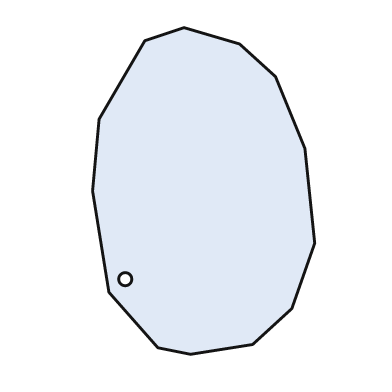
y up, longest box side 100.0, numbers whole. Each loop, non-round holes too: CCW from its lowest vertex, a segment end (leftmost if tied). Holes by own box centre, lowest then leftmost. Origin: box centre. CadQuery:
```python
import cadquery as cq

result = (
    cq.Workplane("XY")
    .moveTo(-4.0, -50.0)
    .lineTo(15.0, -47.0)
    .lineTo(27.0, -36.0)
    .lineTo(34.0, -16.0)
    .lineTo(31.0, 13.0)
    .lineTo(22.0, 35.0)
    .lineTo(11.0, 45.0)
    .lineTo(-6.0, 50.0)
    .lineTo(-18.0, 46.0)
    .lineTo(-32.0, 22.0)
    .lineTo(-34.0, 0.0)
    .lineTo(-29.0, -31.0)
    .lineTo(-14.0, -48.0)
    .close()
    .moveTo(-24.0, -27.0)
    .circle(2.0)
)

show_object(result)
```